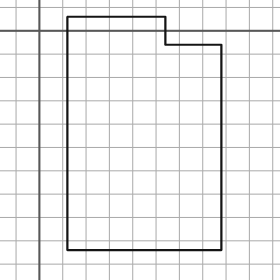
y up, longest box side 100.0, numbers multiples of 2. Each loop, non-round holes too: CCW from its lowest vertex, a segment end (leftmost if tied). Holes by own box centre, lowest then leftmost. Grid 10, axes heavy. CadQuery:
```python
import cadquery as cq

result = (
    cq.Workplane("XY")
    .moveTo(12.0, -94.0)
    .lineTo(78.0, -94.0)
    .lineTo(78.0, -6.0)
    .lineTo(54.0, -6.0)
    .lineTo(54.0, 6.0)
    .lineTo(12.0, 6.0)
    .close()
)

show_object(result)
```